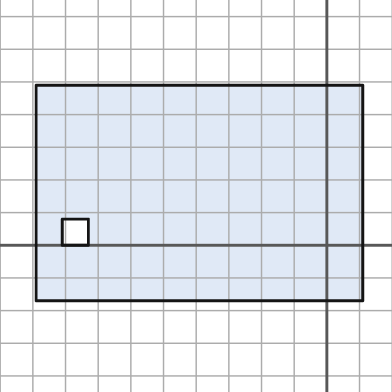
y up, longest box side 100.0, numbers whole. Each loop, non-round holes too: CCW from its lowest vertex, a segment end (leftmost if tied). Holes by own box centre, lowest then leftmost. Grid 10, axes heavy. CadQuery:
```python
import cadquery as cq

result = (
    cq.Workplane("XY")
    .moveTo(-89.0, -17.0)
    .lineTo(11.0, -17.0)
    .lineTo(11.0, 49.0)
    .lineTo(-89.0, 49.0)
    .close()
    .moveTo(-81.0, 0.0)
    .lineTo(-73.0, 0.0)
    .lineTo(-73.0, 8.0)
    .lineTo(-81.0, 8.0)
    .close()
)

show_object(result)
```